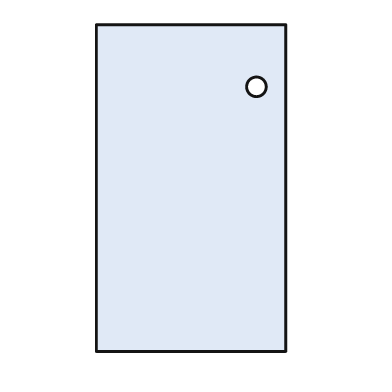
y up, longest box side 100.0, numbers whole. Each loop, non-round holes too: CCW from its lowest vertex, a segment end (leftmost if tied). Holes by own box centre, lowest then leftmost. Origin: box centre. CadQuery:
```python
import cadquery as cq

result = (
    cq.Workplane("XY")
    .moveTo(-29.0, -50.0)
    .lineTo(29.0, -50.0)
    .lineTo(29.0, 50.0)
    .lineTo(-29.0, 50.0)
    .close()
    .moveTo(20.0, 31.0)
    .circle(3.0)
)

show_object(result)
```